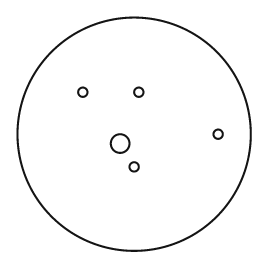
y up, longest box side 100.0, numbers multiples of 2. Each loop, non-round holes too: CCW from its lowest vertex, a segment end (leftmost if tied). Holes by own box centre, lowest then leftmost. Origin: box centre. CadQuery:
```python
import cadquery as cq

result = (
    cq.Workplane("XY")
    .moveTo(0.0, 0.0)
    .circle(50.0)
    .moveTo(0.0, -14.0)
    .circle(2.0)
    .moveTo(-6.0, -4.0)
    .circle(4.0)
    .moveTo(36.0, 0.0)
    .circle(2.0)
    .moveTo(-22.0, 18.0)
    .circle(2.0)
    .moveTo(2.0, 18.0)
    .circle(2.0)
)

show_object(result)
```